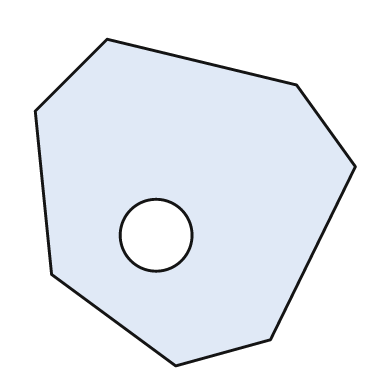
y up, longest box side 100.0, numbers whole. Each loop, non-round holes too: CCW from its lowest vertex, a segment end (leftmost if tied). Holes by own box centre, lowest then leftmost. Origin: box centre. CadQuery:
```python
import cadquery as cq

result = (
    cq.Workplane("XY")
    .moveTo(-6.0, -50.0)
    .lineTo(23.0, -42.0)
    .lineTo(49.0, 11.0)
    .lineTo(31.0, 36.0)
    .lineTo(-27.0, 50.0)
    .lineTo(-49.0, 28.0)
    .lineTo(-44.0, -22.0)
    .close()
    .moveTo(-12.0, -10.0)
    .circle(11.0)
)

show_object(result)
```